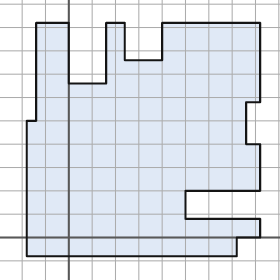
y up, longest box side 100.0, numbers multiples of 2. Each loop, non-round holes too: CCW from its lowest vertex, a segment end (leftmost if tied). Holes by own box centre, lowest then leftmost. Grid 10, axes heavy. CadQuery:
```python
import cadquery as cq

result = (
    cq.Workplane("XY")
    .moveTo(-18.0, -8.0)
    .lineTo(72.0, -8.0)
    .lineTo(72.0, 0.0)
    .lineTo(82.0, 0.0)
    .lineTo(82.0, 8.0)
    .lineTo(50.0, 8.0)
    .lineTo(50.0, 20.0)
    .lineTo(82.0, 20.0)
    .lineTo(82.0, 40.0)
    .lineTo(76.0, 40.0)
    .lineTo(76.0, 58.0)
    .lineTo(82.0, 58.0)
    .lineTo(82.0, 92.0)
    .lineTo(40.0, 92.0)
    .lineTo(40.0, 76.0)
    .lineTo(24.0, 76.0)
    .lineTo(24.0, 92.0)
    .lineTo(16.0, 92.0)
    .lineTo(16.0, 66.0)
    .lineTo(0.0, 66.0)
    .lineTo(0.0, 92.0)
    .lineTo(-14.0, 92.0)
    .lineTo(-14.0, 50.0)
    .lineTo(-18.0, 50.0)
    .close()
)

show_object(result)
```